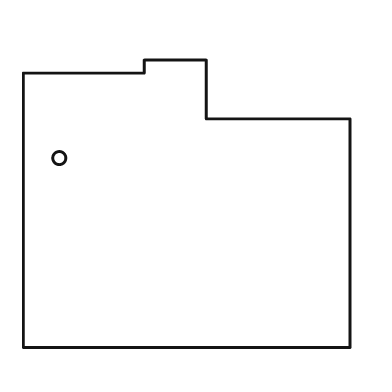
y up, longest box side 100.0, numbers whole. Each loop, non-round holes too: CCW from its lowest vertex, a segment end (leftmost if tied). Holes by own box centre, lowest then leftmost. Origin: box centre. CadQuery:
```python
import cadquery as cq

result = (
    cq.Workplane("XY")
    .moveTo(-50.0, -44.0)
    .lineTo(50.0, -44.0)
    .lineTo(50.0, 26.0)
    .lineTo(6.0, 26.0)
    .lineTo(6.0, 44.0)
    .lineTo(-13.0, 44.0)
    .lineTo(-13.0, 40.0)
    .lineTo(-50.0, 40.0)
    .close()
    .moveTo(-39.0, 14.0)
    .circle(2.0)
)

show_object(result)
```